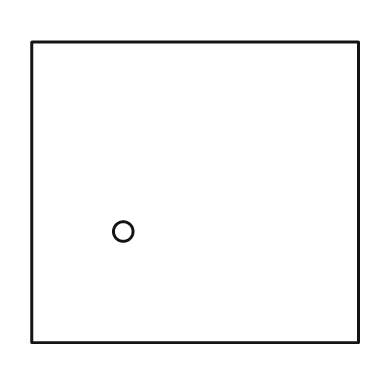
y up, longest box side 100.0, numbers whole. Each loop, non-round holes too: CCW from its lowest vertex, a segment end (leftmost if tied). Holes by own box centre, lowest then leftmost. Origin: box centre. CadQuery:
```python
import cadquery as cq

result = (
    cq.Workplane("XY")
    .moveTo(-50.0, -46.0)
    .lineTo(50.0, -46.0)
    .lineTo(50.0, 46.0)
    .lineTo(-50.0, 46.0)
    .close()
    .moveTo(-22.0, -12.0)
    .circle(3.0)
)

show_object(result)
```